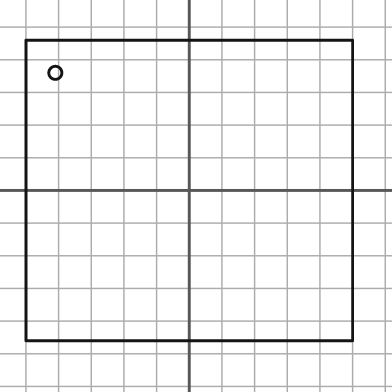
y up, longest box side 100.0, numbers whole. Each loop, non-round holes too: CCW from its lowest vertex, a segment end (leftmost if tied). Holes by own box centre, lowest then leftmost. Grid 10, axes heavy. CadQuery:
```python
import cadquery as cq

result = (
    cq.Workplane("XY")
    .moveTo(-50.0, -46.0)
    .lineTo(50.0, -46.0)
    .lineTo(50.0, 46.0)
    .lineTo(-50.0, 46.0)
    .close()
    .moveTo(-41.0, 36.0)
    .circle(2.0)
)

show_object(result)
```